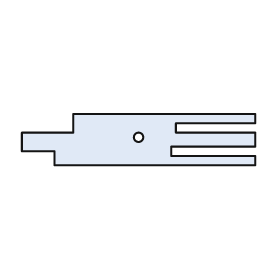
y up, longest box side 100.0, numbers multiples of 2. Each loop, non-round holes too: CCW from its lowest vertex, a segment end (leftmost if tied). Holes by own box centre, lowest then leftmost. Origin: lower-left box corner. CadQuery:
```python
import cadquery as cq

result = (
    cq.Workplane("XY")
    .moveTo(14.0, 0.0)
    .lineTo(100.0, 0.0)
    .lineTo(100.0, 4.0)
    .lineTo(64.0, 4.0)
    .lineTo(64.0, 8.0)
    .lineTo(100.0, 8.0)
    .lineTo(100.0, 14.0)
    .lineTo(66.0, 14.0)
    .lineTo(66.0, 18.0)
    .lineTo(100.0, 18.0)
    .lineTo(100.0, 22.0)
    .lineTo(22.0, 22.0)
    .lineTo(22.0, 14.0)
    .lineTo(0.0, 14.0)
    .lineTo(0.0, 6.0)
    .lineTo(14.0, 6.0)
    .close()
    .moveTo(50.0, 12.0)
    .circle(2.0)
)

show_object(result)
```